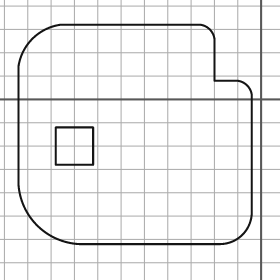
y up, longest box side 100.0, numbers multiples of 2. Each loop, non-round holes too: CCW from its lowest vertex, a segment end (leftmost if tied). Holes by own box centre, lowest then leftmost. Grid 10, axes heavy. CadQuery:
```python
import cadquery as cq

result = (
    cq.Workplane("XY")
    .moveTo(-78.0, -62.0)
    .lineTo(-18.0, -62.0)
    .threePointArc((-8.0, -58.0), (-4.0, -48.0))
    .lineTo(-4.0, 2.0)
    .threePointArc((-6.0, 6.0), (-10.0, 8.0))
    .lineTo(-20.0, 8.0)
    .lineTo(-20.0, 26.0)
    .threePointArc((-22.0, 30.0), (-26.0, 32.0))
    .lineTo(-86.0, 32.0)
    .threePointArc((-98.0, 26.0), (-104.0, 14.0))
    .lineTo(-104.0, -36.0)
    .threePointArc((-96.0, -54.0), (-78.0, -62.0))
    .close()
    .moveTo(-88.0, -28.0)
    .lineTo(-72.0, -28.0)
    .lineTo(-72.0, -12.0)
    .lineTo(-88.0, -12.0)
    .close()
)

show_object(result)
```